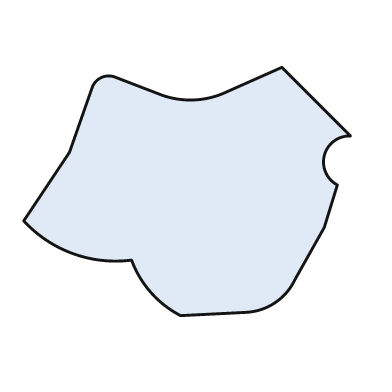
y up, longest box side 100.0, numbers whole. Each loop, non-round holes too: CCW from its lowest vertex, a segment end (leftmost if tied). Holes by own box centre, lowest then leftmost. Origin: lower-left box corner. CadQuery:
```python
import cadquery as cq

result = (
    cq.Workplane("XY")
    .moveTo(48.0, 0.0)
    .lineTo(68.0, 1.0)
    .threePointArc((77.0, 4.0), (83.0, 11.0))
    .lineTo(92.0, 27.0)
    .lineTo(96.0, 40.0)
    .threePointArc((92.0, 49.0), (100.0, 55.0))
    .lineTo(79.0, 76.0)
    .lineTo(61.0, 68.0)
    .threePointArc((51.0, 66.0), (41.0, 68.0))
    .lineTo(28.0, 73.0)
    .threePointArc((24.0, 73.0), (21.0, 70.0))
    .lineTo(14.0, 50.0)
    .lineTo(0.0, 29.0)
    .threePointArc((15.0, 19.0), (33.0, 17.0))
    .threePointArc((39.0, 7.0), (48.0, 0.0))
    .close()
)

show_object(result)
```